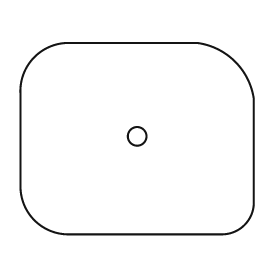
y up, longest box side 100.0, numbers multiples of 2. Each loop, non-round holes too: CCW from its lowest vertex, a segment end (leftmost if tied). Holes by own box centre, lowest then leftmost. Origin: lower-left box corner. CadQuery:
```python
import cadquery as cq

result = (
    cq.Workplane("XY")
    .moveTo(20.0, 0.0)
    .lineTo(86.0, 0.0)
    .threePointArc((96.0, 4.0), (100.0, 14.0))
    .lineTo(100.0, 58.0)
    .threePointArc((92.0, 74.0), (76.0, 82.0))
    .lineTo(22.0, 82.0)
    .threePointArc((6.0, 76.0), (0.0, 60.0))
    .lineTo(0.0, 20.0)
    .threePointArc((6.0, 6.0), (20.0, 0.0))
    .close()
    .moveTo(50.0, 42.0)
    .circle(4.0)
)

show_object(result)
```